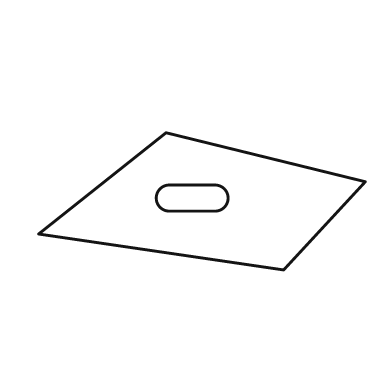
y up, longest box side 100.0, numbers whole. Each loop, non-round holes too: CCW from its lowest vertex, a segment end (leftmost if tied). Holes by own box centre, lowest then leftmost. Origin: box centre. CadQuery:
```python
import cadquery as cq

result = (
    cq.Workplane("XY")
    .moveTo(25.0, -21.0)
    .lineTo(50.0, 6.0)
    .lineTo(-11.0, 21.0)
    .lineTo(-50.0, -10.0)
    .close()
    .moveTo(-10.0, -3.0)
    .lineTo(4.0, -3.0)
    .threePointArc((8.0, 1.0), (4.0, 5.0))
    .lineTo(-10.0, 5.0)
    .threePointArc((-14.0, 1.0), (-10.0, -3.0))
    .close()
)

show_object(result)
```